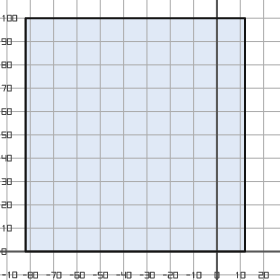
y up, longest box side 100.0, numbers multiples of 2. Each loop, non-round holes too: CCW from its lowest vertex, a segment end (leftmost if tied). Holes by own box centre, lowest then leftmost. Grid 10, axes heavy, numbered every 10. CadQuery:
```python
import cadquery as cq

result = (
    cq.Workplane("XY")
    .moveTo(-82.0, 0.0)
    .lineTo(12.0, 0.0)
    .lineTo(12.0, 100.0)
    .lineTo(-82.0, 100.0)
    .close()
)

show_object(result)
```